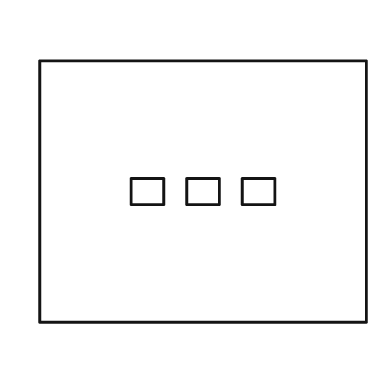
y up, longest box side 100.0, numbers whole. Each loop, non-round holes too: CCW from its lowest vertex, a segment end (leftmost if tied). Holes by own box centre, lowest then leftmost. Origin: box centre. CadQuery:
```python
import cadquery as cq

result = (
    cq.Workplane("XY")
    .moveTo(-50.0, -40.0)
    .lineTo(50.0, -40.0)
    .lineTo(50.0, 40.0)
    .lineTo(-50.0, 40.0)
    .close()
    .moveTo(-22.0, -4.0)
    .lineTo(-12.0, -4.0)
    .lineTo(-12.0, 4.0)
    .lineTo(-22.0, 4.0)
    .close()
    .moveTo(-5.0, -4.0)
    .lineTo(5.0, -4.0)
    .lineTo(5.0, 4.0)
    .lineTo(-5.0, 4.0)
    .close()
    .moveTo(12.0, -4.0)
    .lineTo(22.0, -4.0)
    .lineTo(22.0, 4.0)
    .lineTo(12.0, 4.0)
    .close()
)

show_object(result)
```